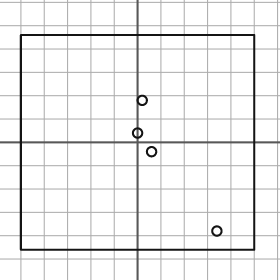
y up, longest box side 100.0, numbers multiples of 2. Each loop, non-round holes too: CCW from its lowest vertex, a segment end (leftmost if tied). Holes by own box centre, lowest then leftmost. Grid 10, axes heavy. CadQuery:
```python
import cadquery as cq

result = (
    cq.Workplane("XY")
    .moveTo(-50.0, -46.0)
    .lineTo(50.0, -46.0)
    .lineTo(50.0, 46.0)
    .lineTo(-50.0, 46.0)
    .close()
    .moveTo(34.0, -38.0)
    .circle(2.0)
    .moveTo(6.0, -4.0)
    .circle(2.0)
    .moveTo(0.0, 4.0)
    .circle(2.0)
    .moveTo(2.0, 18.0)
    .circle(2.0)
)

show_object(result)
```